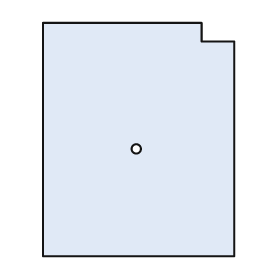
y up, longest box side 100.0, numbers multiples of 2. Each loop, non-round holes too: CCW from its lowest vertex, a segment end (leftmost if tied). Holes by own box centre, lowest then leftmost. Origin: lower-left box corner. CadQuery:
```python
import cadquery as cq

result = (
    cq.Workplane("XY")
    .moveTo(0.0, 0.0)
    .lineTo(82.0, 0.0)
    .lineTo(82.0, 92.0)
    .lineTo(68.0, 92.0)
    .lineTo(68.0, 100.0)
    .lineTo(0.0, 100.0)
    .close()
    .moveTo(40.0, 46.0)
    .circle(2.0)
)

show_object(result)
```